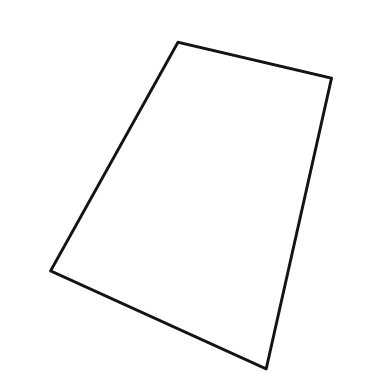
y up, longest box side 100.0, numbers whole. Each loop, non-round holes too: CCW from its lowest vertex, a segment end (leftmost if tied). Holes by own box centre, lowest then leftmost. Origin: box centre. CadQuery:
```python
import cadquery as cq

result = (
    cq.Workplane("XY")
    .moveTo(23.0, -50.0)
    .lineTo(43.0, 39.0)
    .lineTo(-4.0, 50.0)
    .lineTo(-43.0, -20.0)
    .close()
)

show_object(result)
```